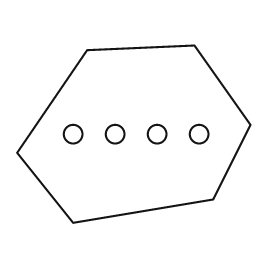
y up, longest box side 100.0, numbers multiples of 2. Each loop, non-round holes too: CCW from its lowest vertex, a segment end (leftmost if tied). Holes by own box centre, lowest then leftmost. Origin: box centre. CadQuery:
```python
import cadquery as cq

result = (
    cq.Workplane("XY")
    .moveTo(-26.0, -38.0)
    .lineTo(34.0, -28.0)
    .lineTo(50.0, 4.0)
    .lineTo(26.0, 38.0)
    .lineTo(-20.0, 36.0)
    .lineTo(-50.0, -8.0)
    .close()
    .moveTo(-26.0, 0.0)
    .circle(4.0)
    .moveTo(-8.0, 0.0)
    .circle(4.0)
    .moveTo(10.0, 0.0)
    .circle(4.0)
    .moveTo(28.0, 0.0)
    .circle(4.0)
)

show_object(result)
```